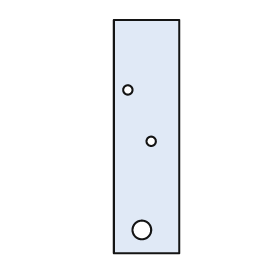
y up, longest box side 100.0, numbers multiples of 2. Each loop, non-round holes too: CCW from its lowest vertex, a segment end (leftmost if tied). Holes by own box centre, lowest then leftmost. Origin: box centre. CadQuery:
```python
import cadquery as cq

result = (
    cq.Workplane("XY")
    .moveTo(-14.0, -50.0)
    .lineTo(14.0, -50.0)
    .lineTo(14.0, 50.0)
    .lineTo(-14.0, 50.0)
    .close()
    .moveTo(-2.0, -40.0)
    .circle(4.0)
    .moveTo(2.0, -2.0)
    .circle(2.0)
    .moveTo(-8.0, 20.0)
    .circle(2.0)
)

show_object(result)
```